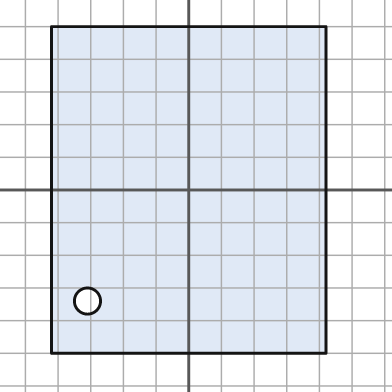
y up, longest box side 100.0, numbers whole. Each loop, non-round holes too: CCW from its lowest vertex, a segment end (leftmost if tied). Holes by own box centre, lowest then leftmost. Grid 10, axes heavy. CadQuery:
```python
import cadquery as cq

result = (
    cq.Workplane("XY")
    .moveTo(-42.0, -50.0)
    .lineTo(42.0, -50.0)
    .lineTo(42.0, 50.0)
    .lineTo(-42.0, 50.0)
    .close()
    .moveTo(-31.0, -34.0)
    .circle(4.0)
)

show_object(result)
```